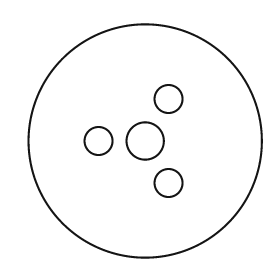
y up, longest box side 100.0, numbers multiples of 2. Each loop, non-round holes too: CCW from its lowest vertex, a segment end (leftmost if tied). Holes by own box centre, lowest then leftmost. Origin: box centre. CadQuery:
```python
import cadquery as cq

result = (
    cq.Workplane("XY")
    .moveTo(0.0, 0.0)
    .circle(50.0)
    .moveTo(10.0, -18.0)
    .circle(6.0)
    .moveTo(-20.0, 0.0)
    .circle(6.0)
    .moveTo(0.0, 0.0)
    .circle(8.0)
    .moveTo(10.0, 18.0)
    .circle(6.0)
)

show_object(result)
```